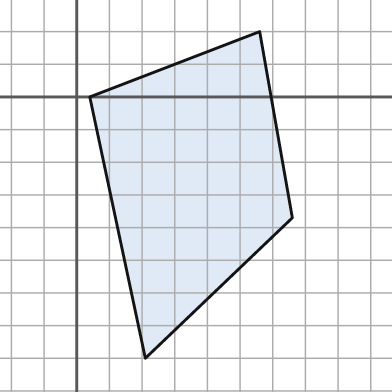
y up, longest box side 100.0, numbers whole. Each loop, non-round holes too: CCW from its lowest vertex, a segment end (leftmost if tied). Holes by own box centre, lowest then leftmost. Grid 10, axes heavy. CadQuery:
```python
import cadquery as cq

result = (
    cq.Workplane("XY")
    .moveTo(21.0, -80.0)
    .lineTo(66.0, -37.0)
    .lineTo(56.0, 20.0)
    .lineTo(4.0, 0.0)
    .close()
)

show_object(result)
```